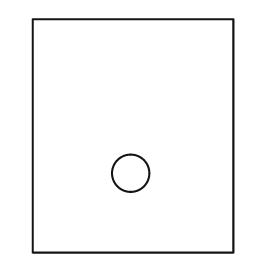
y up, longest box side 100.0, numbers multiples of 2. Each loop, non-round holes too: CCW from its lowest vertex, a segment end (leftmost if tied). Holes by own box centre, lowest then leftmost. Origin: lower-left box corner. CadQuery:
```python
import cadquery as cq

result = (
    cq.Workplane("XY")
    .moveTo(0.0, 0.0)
    .lineTo(86.0, 0.0)
    .lineTo(86.0, 100.0)
    .lineTo(0.0, 100.0)
    .close()
    .moveTo(42.0, 34.0)
    .circle(8.0)
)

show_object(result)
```